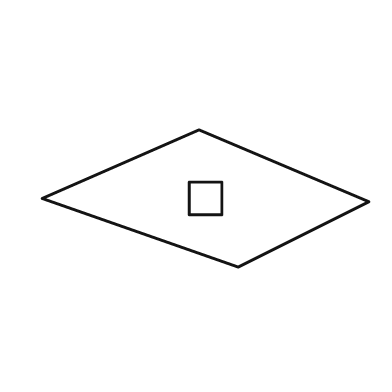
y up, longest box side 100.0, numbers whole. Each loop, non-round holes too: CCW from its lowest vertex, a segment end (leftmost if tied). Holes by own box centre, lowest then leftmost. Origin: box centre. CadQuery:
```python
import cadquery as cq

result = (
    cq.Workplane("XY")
    .moveTo(10.0, -21.0)
    .lineTo(50.0, -1.0)
    .lineTo(-2.0, 21.0)
    .lineTo(-50.0, 0.0)
    .close()
    .moveTo(-5.0, -5.0)
    .lineTo(5.0, -5.0)
    .lineTo(5.0, 5.0)
    .lineTo(-5.0, 5.0)
    .close()
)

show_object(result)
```